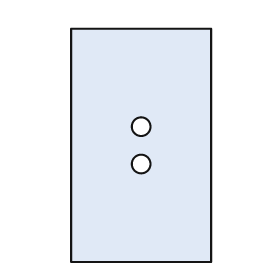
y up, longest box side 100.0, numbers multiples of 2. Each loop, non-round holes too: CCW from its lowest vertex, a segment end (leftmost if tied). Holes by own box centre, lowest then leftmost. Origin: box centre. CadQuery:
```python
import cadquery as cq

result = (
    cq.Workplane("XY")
    .moveTo(-30.0, -50.0)
    .lineTo(30.0, -50.0)
    .lineTo(30.0, 50.0)
    .lineTo(-30.0, 50.0)
    .close()
    .moveTo(0.0, -8.0)
    .circle(4.0)
    .moveTo(0.0, 8.0)
    .circle(4.0)
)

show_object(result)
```